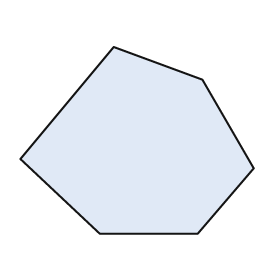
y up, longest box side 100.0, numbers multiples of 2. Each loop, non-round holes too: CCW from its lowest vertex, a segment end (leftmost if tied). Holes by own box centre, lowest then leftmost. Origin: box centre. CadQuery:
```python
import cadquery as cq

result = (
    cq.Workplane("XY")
    .moveTo(-16.0, -40.0)
    .lineTo(26.0, -40.0)
    .lineTo(50.0, -12.0)
    .lineTo(28.0, 26.0)
    .lineTo(-10.0, 40.0)
    .lineTo(-50.0, -8.0)
    .close()
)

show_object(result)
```